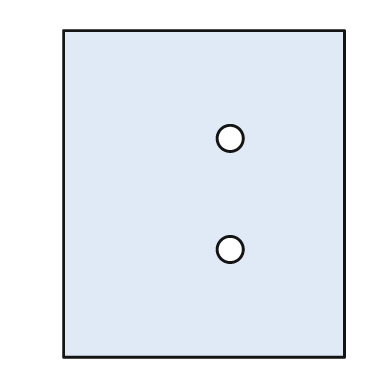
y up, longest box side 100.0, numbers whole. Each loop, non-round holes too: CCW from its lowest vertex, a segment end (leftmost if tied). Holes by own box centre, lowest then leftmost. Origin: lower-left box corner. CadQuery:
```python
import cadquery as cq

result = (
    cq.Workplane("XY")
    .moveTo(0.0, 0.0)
    .lineTo(86.0, 0.0)
    .lineTo(86.0, 100.0)
    .lineTo(0.0, 100.0)
    .close()
    .moveTo(51.0, 33.0)
    .circle(4.0)
    .moveTo(51.0, 67.0)
    .circle(4.0)
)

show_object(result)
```